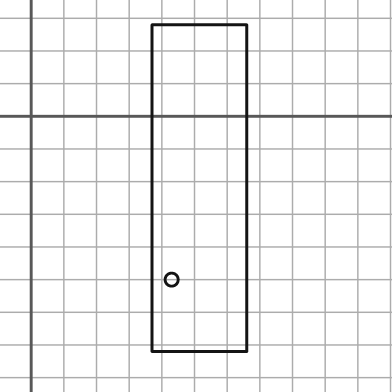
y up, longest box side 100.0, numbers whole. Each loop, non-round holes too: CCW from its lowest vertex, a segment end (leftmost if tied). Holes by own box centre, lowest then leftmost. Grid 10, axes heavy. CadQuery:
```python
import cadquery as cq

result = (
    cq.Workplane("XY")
    .moveTo(37.0, -72.0)
    .lineTo(66.0, -72.0)
    .lineTo(66.0, 28.0)
    .lineTo(37.0, 28.0)
    .close()
    .moveTo(43.0, -50.0)
    .circle(2.0)
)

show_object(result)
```